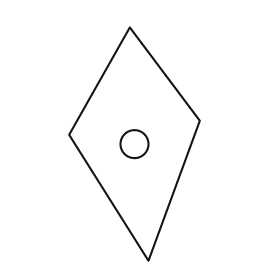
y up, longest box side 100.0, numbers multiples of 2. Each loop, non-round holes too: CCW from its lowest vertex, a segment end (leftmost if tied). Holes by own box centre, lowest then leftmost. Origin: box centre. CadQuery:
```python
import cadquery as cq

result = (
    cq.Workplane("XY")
    .moveTo(6.0, -50.0)
    .lineTo(28.0, 10.0)
    .lineTo(-2.0, 50.0)
    .lineTo(-28.0, 4.0)
    .close()
    .moveTo(0.0, 0.0)
    .circle(6.0)
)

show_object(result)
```